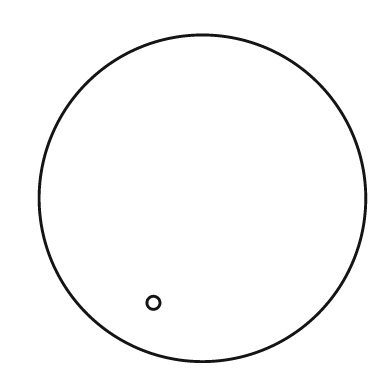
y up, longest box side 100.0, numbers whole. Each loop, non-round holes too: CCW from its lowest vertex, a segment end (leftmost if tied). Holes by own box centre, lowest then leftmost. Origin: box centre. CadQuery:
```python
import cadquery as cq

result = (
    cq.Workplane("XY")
    .moveTo(0.0, 0.0)
    .circle(50.0)
    .moveTo(-15.0, -32.0)
    .circle(2.0)
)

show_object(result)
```